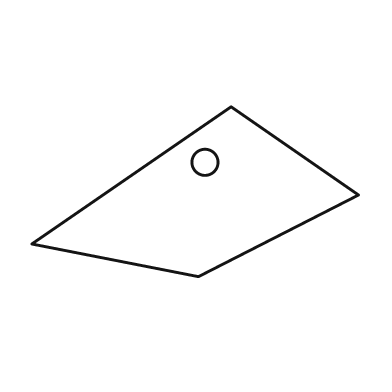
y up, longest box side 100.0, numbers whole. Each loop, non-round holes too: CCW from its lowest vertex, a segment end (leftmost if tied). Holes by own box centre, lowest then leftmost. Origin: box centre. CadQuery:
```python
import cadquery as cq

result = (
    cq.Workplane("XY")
    .moveTo(1.0, -26.0)
    .lineTo(50.0, -1.0)
    .lineTo(11.0, 26.0)
    .lineTo(-50.0, -16.0)
    .close()
    .moveTo(3.0, 9.0)
    .circle(4.0)
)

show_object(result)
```